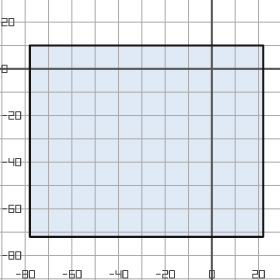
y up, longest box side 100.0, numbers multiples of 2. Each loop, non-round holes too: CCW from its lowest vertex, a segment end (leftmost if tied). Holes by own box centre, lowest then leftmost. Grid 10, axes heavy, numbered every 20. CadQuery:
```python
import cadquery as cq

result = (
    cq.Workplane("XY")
    .moveTo(-78.0, -72.0)
    .lineTo(22.0, -72.0)
    .lineTo(22.0, 10.0)
    .lineTo(-78.0, 10.0)
    .close()
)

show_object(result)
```